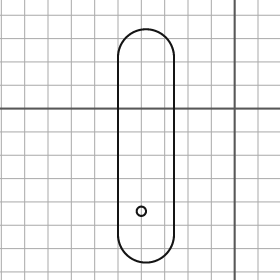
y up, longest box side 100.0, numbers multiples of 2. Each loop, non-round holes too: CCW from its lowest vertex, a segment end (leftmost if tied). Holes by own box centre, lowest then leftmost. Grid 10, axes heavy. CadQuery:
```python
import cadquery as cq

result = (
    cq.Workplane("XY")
    .moveTo(-50.0, -54.0)
    .threePointArc((-38.0, -66.0), (-26.0, -54.0))
    .lineTo(-26.0, 22.0)
    .threePointArc((-38.0, 34.0), (-50.0, 22.0))
    .close()
    .moveTo(-40.0, -44.0)
    .circle(2.0)
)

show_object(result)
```